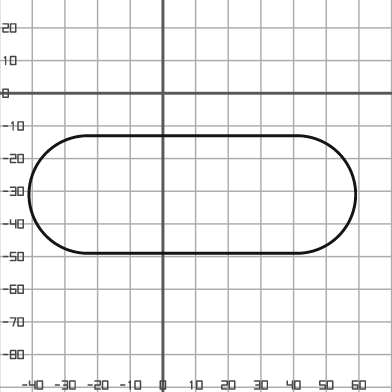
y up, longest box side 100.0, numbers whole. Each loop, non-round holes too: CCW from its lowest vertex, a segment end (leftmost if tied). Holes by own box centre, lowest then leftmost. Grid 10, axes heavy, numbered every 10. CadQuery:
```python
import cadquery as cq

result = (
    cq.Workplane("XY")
    .moveTo(-23.0, -49.0)
    .lineTo(41.0, -49.0)
    .threePointArc((59.0, -31.0), (41.0, -13.0))
    .lineTo(-23.0, -13.0)
    .threePointArc((-41.0, -31.0), (-23.0, -49.0))
    .close()
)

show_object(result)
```